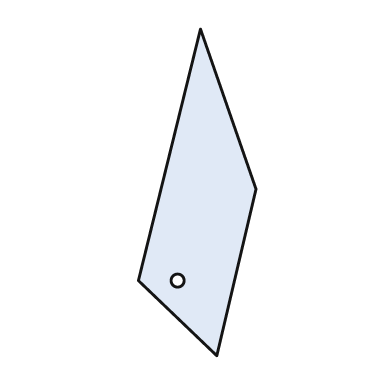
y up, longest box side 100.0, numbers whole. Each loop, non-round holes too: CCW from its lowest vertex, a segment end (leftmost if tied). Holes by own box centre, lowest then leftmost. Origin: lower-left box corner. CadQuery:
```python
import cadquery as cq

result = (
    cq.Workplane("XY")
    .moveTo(24.0, 0.0)
    .lineTo(36.0, 51.0)
    .lineTo(19.0, 100.0)
    .lineTo(0.0, 23.0)
    .close()
    .moveTo(12.0, 23.0)
    .circle(2.0)
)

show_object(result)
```